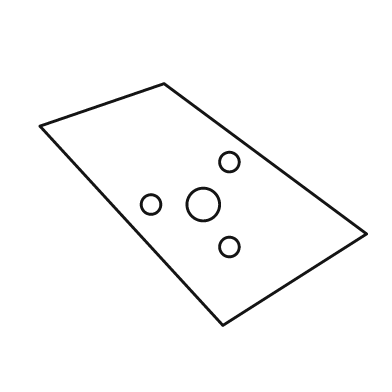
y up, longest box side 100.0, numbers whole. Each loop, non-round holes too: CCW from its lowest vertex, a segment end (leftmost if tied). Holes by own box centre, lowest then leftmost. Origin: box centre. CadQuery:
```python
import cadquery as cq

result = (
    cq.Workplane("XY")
    .moveTo(6.0, -37.0)
    .lineTo(50.0, -9.0)
    .lineTo(-12.0, 37.0)
    .lineTo(-50.0, 24.0)
    .close()
    .moveTo(8.0, -13.0)
    .circle(3.0)
    .moveTo(-16.0, 0.0)
    .circle(3.0)
    .moveTo(0.0, 0.0)
    .circle(5.0)
    .moveTo(8.0, 13.0)
    .circle(3.0)
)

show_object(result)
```